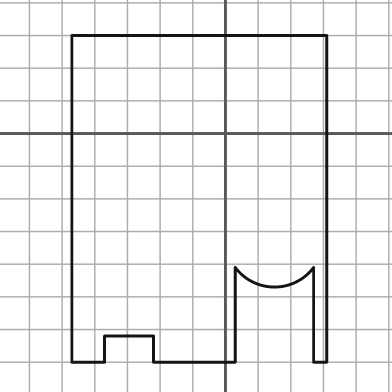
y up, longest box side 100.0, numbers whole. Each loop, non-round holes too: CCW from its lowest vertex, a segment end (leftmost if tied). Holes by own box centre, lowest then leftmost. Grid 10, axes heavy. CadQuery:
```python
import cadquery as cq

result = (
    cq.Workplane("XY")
    .moveTo(-47.0, -70.0)
    .lineTo(-37.0, -70.0)
    .lineTo(-37.0, -62.0)
    .lineTo(-22.0, -62.0)
    .lineTo(-22.0, -70.0)
    .lineTo(3.0, -70.0)
    .lineTo(3.0, -41.0)
    .threePointArc((15.0, -47.0), (27.0, -41.0))
    .lineTo(27.0, -70.0)
    .lineTo(31.0, -70.0)
    .lineTo(31.0, 30.0)
    .lineTo(-47.0, 30.0)
    .close()
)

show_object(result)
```